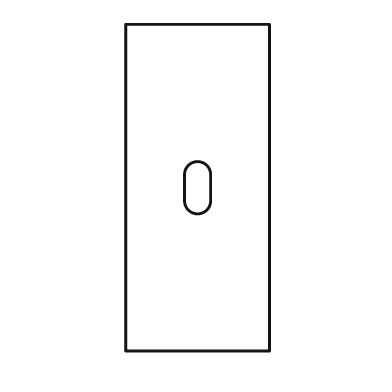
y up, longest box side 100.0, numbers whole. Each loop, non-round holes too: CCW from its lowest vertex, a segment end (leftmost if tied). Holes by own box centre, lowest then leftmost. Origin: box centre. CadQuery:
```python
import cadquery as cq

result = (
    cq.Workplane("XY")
    .moveTo(-22.0, -50.0)
    .lineTo(22.0, -50.0)
    .lineTo(22.0, 50.0)
    .lineTo(-22.0, 50.0)
    .close()
    .moveTo(-4.0, -4.0)
    .threePointArc((0.0, -8.0), (4.0, -4.0))
    .lineTo(4.0, 4.0)
    .threePointArc((0.0, 8.0), (-4.0, 4.0))
    .close()
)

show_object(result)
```